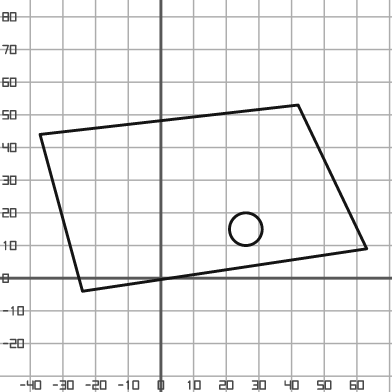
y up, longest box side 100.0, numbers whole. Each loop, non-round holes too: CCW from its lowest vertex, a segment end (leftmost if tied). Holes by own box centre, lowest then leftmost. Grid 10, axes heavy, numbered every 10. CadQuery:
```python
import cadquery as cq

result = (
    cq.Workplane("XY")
    .moveTo(-24.0, -4.0)
    .lineTo(63.0, 9.0)
    .lineTo(42.0, 53.0)
    .lineTo(-37.0, 44.0)
    .close()
    .moveTo(26.0, 15.0)
    .circle(5.0)
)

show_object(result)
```